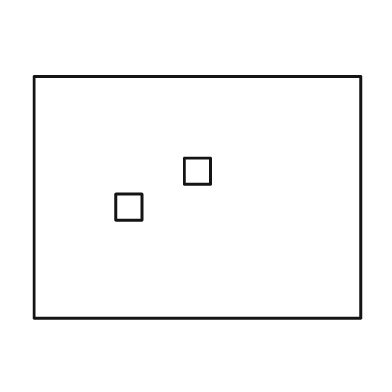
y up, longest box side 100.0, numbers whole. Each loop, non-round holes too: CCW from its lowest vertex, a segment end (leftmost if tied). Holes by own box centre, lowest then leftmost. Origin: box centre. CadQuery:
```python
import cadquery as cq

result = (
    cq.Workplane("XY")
    .moveTo(-50.0, -37.0)
    .lineTo(50.0, -37.0)
    .lineTo(50.0, 37.0)
    .lineTo(-50.0, 37.0)
    .close()
    .moveTo(-25.0, -7.0)
    .lineTo(-17.0, -7.0)
    .lineTo(-17.0, 1.0)
    .lineTo(-25.0, 1.0)
    .close()
    .moveTo(-4.0, 4.0)
    .lineTo(4.0, 4.0)
    .lineTo(4.0, 12.0)
    .lineTo(-4.0, 12.0)
    .close()
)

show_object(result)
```